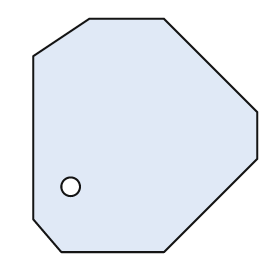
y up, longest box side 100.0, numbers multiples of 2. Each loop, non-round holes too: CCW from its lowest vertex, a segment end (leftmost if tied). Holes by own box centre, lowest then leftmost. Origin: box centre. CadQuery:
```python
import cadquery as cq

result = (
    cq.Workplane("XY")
    .moveTo(-36.0, -50.0)
    .lineTo(8.0, -50.0)
    .lineTo(48.0, -10.0)
    .lineTo(48.0, 10.0)
    .lineTo(8.0, 50.0)
    .lineTo(-24.0, 50.0)
    .lineTo(-48.0, 34.0)
    .lineTo(-48.0, -36.0)
    .close()
    .moveTo(-32.0, -22.0)
    .circle(4.0)
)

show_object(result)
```